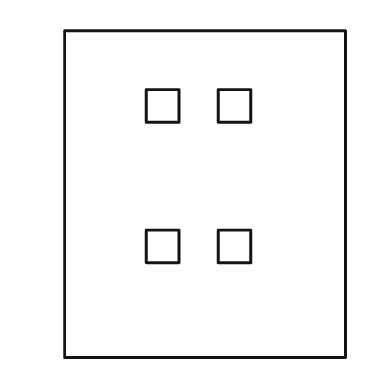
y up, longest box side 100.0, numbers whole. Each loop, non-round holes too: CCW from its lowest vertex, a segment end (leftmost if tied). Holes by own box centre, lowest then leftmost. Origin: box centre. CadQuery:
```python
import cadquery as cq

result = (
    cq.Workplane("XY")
    .moveTo(-43.0, -50.0)
    .lineTo(43.0, -50.0)
    .lineTo(43.0, 50.0)
    .lineTo(-43.0, 50.0)
    .close()
    .moveTo(-18.0, -21.0)
    .lineTo(-8.0, -21.0)
    .lineTo(-8.0, -11.0)
    .lineTo(-18.0, -11.0)
    .close()
    .moveTo(4.0, -21.0)
    .lineTo(14.0, -21.0)
    .lineTo(14.0, -11.0)
    .lineTo(4.0, -11.0)
    .close()
    .moveTo(-18.0, 22.0)
    .lineTo(-8.0, 22.0)
    .lineTo(-8.0, 32.0)
    .lineTo(-18.0, 32.0)
    .close()
    .moveTo(4.0, 22.0)
    .lineTo(14.0, 22.0)
    .lineTo(14.0, 32.0)
    .lineTo(4.0, 32.0)
    .close()
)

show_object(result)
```